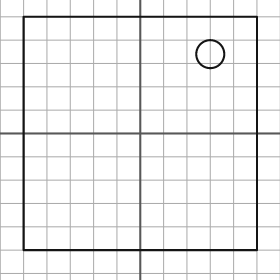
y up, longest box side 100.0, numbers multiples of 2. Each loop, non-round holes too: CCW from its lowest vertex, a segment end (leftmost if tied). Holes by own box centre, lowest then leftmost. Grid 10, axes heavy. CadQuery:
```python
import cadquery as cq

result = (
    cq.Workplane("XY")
    .moveTo(-50.0, -50.0)
    .lineTo(50.0, -50.0)
    .lineTo(50.0, 50.0)
    .lineTo(-50.0, 50.0)
    .close()
    .moveTo(30.0, 34.0)
    .circle(6.0)
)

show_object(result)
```